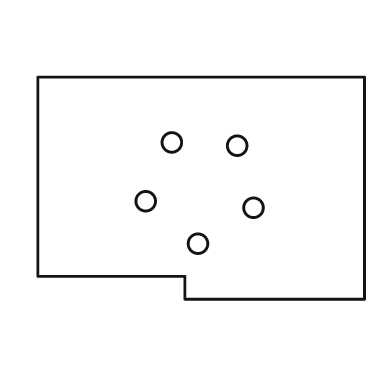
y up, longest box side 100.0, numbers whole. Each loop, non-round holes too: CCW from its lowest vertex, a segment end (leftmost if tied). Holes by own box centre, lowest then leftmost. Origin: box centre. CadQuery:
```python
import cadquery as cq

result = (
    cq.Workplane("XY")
    .moveTo(-5.0, -34.0)
    .lineTo(50.0, -34.0)
    .lineTo(50.0, 34.0)
    .lineTo(-50.0, 34.0)
    .lineTo(-50.0, -27.0)
    .lineTo(-5.0, -27.0)
    .close()
    .moveTo(-1.0, -17.0)
    .circle(3.0)
    .moveTo(16.0, -6.0)
    .circle(3.0)
    .moveTo(-17.0, -4.0)
    .circle(3.0)
    .moveTo(11.0, 13.0)
    .circle(3.0)
    .moveTo(-9.0, 14.0)
    .circle(3.0)
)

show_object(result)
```